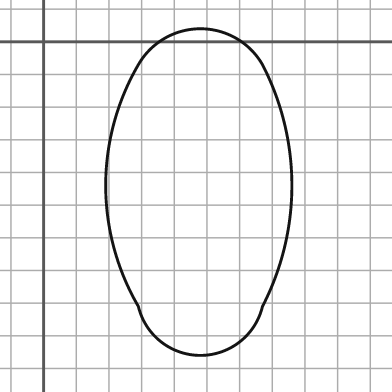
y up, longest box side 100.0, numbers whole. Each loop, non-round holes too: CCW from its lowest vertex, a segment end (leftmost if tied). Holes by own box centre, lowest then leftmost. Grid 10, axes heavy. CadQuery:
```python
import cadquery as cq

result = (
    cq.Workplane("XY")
    .moveTo(29.0, -81.0)
    .threePointArc((48.0, -96.0), (67.0, -81.0))
    .threePointArc((76.0, -44.0), (67.0, -7.0))
    .threePointArc((48.0, 4.0), (29.0, -7.0))
    .threePointArc((19.0, -44.0), (29.0, -81.0))
    .close()
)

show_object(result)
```